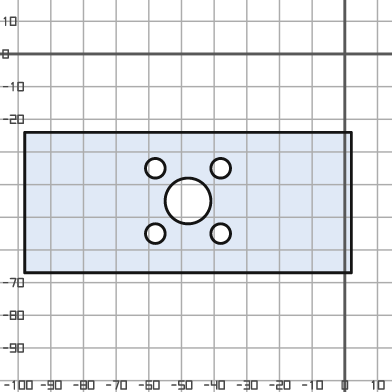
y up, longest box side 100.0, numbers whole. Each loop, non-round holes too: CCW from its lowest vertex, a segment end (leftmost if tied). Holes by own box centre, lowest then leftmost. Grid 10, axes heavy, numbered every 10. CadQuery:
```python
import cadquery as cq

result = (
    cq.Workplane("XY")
    .moveTo(-98.0, -67.0)
    .lineTo(2.0, -67.0)
    .lineTo(2.0, -24.0)
    .lineTo(-98.0, -24.0)
    .close()
    .moveTo(-58.0, -55.0)
    .circle(3.0)
    .moveTo(-38.0, -55.0)
    .circle(3.0)
    .moveTo(-48.0, -45.0)
    .circle(7.0)
    .moveTo(-58.0, -35.0)
    .circle(3.0)
    .moveTo(-38.0, -35.0)
    .circle(3.0)
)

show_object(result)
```